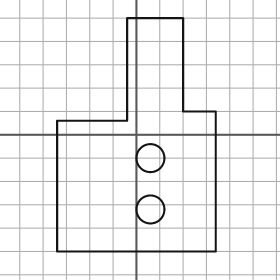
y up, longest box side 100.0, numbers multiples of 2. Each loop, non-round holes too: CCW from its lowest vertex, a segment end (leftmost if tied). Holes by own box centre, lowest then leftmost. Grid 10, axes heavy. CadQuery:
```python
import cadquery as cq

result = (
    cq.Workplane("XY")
    .moveTo(-34.0, -50.0)
    .lineTo(34.0, -50.0)
    .lineTo(34.0, 10.0)
    .lineTo(20.0, 10.0)
    .lineTo(20.0, 50.0)
    .lineTo(-4.0, 50.0)
    .lineTo(-4.0, 6.0)
    .lineTo(-34.0, 6.0)
    .close()
    .moveTo(6.0, -32.0)
    .circle(6.0)
    .moveTo(6.0, -10.0)
    .circle(6.0)
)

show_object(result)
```